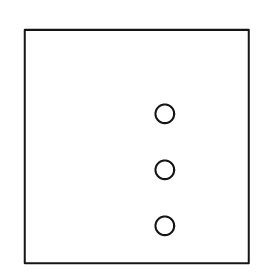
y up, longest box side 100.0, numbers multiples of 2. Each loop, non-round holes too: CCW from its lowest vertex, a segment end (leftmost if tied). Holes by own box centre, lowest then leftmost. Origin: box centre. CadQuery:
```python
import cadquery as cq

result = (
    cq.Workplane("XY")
    .moveTo(-48.0, -50.0)
    .lineTo(48.0, -50.0)
    .lineTo(48.0, 50.0)
    .lineTo(-48.0, 50.0)
    .close()
    .moveTo(12.0, -34.0)
    .circle(4.0)
    .moveTo(12.0, -10.0)
    .circle(4.0)
    .moveTo(12.0, 14.0)
    .circle(4.0)
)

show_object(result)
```